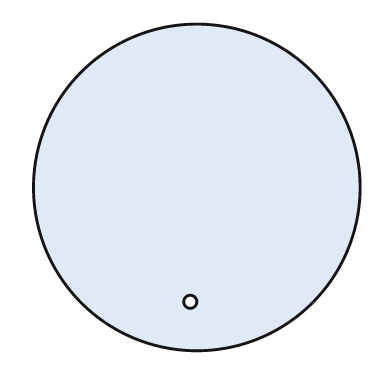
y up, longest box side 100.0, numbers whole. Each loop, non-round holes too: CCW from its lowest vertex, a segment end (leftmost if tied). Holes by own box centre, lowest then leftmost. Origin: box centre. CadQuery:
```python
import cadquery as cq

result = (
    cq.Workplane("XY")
    .moveTo(0.0, 0.0)
    .circle(50.0)
    .moveTo(-2.0, -35.0)
    .circle(2.0)
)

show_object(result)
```